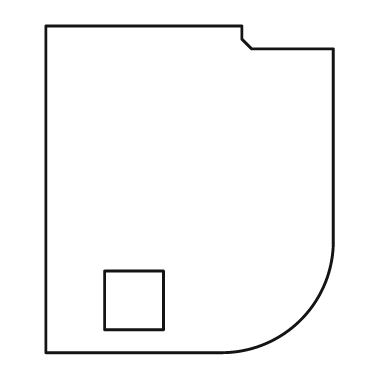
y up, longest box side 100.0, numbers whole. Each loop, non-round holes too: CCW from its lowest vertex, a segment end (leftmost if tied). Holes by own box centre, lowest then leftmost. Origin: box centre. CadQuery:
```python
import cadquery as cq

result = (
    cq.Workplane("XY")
    .moveTo(-44.0, -50.0)
    .lineTo(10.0, -50.0)
    .threePointArc((34.0, -40.0), (44.0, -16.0))
    .lineTo(44.0, 43.0)
    .lineTo(19.0, 43.0)
    .lineTo(16.0, 46.0)
    .lineTo(16.0, 50.0)
    .lineTo(-44.0, 50.0)
    .close()
    .moveTo(-26.0, -43.0)
    .lineTo(-8.0, -43.0)
    .lineTo(-8.0, -25.0)
    .lineTo(-26.0, -25.0)
    .close()
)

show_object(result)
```